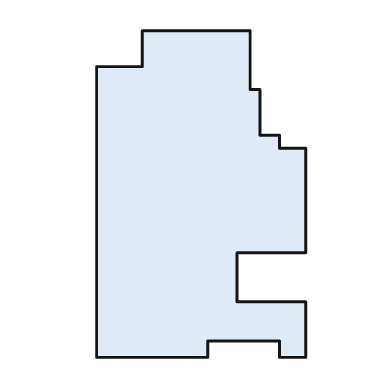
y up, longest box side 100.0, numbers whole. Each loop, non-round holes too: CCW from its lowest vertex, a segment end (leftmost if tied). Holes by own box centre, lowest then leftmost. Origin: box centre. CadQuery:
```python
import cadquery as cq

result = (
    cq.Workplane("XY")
    .moveTo(-32.0, -50.0)
    .lineTo(2.0, -50.0)
    .lineTo(2.0, -45.0)
    .lineTo(24.0, -45.0)
    .lineTo(24.0, -50.0)
    .lineTo(32.0, -50.0)
    .lineTo(32.0, -33.0)
    .lineTo(11.0, -33.0)
    .lineTo(11.0, -18.0)
    .lineTo(32.0, -18.0)
    .lineTo(32.0, 14.0)
    .lineTo(24.0, 14.0)
    .lineTo(24.0, 18.0)
    .lineTo(18.0, 18.0)
    .lineTo(18.0, 32.0)
    .lineTo(15.0, 32.0)
    .lineTo(15.0, 50.0)
    .lineTo(-18.0, 50.0)
    .lineTo(-18.0, 39.0)
    .lineTo(-32.0, 39.0)
    .close()
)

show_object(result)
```